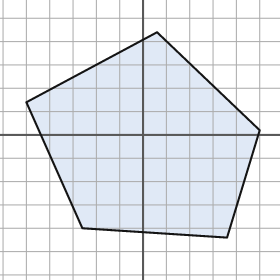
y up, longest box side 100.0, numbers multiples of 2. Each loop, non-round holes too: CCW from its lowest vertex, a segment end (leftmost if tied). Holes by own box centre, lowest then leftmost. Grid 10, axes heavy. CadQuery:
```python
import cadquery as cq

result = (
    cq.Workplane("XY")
    .moveTo(36.0, -44.0)
    .lineTo(50.0, 2.0)
    .lineTo(6.0, 44.0)
    .lineTo(-50.0, 14.0)
    .lineTo(-26.0, -40.0)
    .close()
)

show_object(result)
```